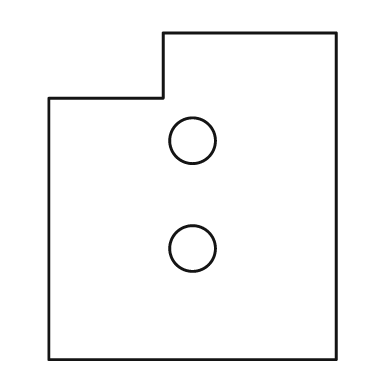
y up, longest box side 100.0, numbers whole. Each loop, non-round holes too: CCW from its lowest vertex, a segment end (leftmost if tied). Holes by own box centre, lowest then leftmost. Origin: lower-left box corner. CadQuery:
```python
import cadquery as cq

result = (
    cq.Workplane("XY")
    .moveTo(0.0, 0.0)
    .lineTo(88.0, 0.0)
    .lineTo(88.0, 100.0)
    .lineTo(35.0, 100.0)
    .lineTo(35.0, 80.0)
    .lineTo(0.0, 80.0)
    .close()
    .moveTo(44.0, 34.0)
    .circle(7.0)
    .moveTo(44.0, 67.0)
    .circle(7.0)
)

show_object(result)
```